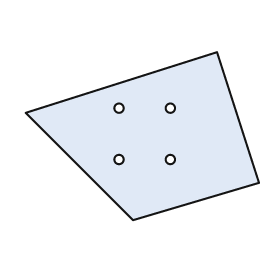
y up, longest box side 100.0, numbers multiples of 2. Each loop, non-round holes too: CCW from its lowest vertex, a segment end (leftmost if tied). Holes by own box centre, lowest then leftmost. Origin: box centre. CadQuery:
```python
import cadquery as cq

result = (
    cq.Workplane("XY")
    .moveTo(-4.0, -36.0)
    .lineTo(50.0, -20.0)
    .lineTo(32.0, 36.0)
    .lineTo(-50.0, 10.0)
    .close()
    .moveTo(-10.0, -10.0)
    .circle(2.0)
    .moveTo(12.0, -10.0)
    .circle(2.0)
    .moveTo(-10.0, 12.0)
    .circle(2.0)
    .moveTo(12.0, 12.0)
    .circle(2.0)
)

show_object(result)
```